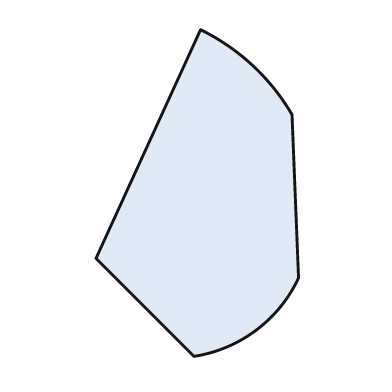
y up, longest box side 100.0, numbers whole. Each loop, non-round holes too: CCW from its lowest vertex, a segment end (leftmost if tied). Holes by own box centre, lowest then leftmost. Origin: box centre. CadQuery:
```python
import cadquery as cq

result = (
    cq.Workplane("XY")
    .moveTo(-1.0, -50.0)
    .threePointArc((18.0, -42.0), (31.0, -26.0))
    .lineTo(29.0, 24.0)
    .threePointArc((17.0, 39.0), (1.0, 50.0))
    .lineTo(-31.0, -20.0)
    .close()
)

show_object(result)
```